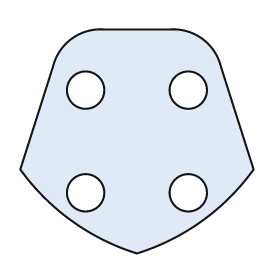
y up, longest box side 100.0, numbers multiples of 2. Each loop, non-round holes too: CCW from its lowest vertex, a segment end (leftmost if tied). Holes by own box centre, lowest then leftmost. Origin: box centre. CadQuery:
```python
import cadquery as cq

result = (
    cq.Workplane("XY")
    .moveTo(0.0, -48.0)
    .threePointArc((28.0, -34.0), (50.0, -12.0))
    .lineTo(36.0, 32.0)
    .threePointArc((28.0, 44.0), (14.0, 48.0))
    .lineTo(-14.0, 48.0)
    .threePointArc((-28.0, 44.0), (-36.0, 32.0))
    .lineTo(-50.0, -12.0)
    .threePointArc((-28.0, -34.0), (0.0, -48.0))
    .close()
    .moveTo(-22.0, -22.0)
    .circle(8.0)
    .moveTo(22.0, -22.0)
    .circle(8.0)
    .moveTo(-22.0, 22.0)
    .circle(8.0)
    .moveTo(22.0, 22.0)
    .circle(8.0)
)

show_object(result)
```